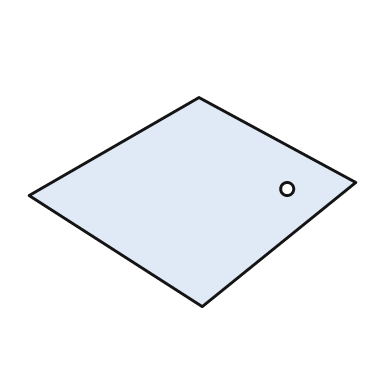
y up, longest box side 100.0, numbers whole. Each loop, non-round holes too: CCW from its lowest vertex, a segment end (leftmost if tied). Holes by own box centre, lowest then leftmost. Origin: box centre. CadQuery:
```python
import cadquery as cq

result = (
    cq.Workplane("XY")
    .moveTo(3.0, -32.0)
    .lineTo(50.0, 6.0)
    .lineTo(2.0, 32.0)
    .lineTo(-50.0, 2.0)
    .close()
    .moveTo(29.0, 4.0)
    .circle(2.0)
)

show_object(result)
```